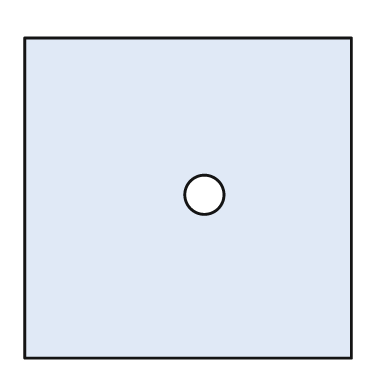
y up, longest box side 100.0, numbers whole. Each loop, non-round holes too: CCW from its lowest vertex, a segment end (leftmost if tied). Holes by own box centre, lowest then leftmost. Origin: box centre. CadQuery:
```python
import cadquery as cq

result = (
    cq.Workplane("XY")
    .moveTo(-50.0, -49.0)
    .lineTo(50.0, -49.0)
    .lineTo(50.0, 49.0)
    .lineTo(-50.0, 49.0)
    .close()
    .moveTo(5.0, 1.0)
    .circle(6.0)
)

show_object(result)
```